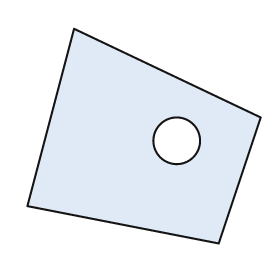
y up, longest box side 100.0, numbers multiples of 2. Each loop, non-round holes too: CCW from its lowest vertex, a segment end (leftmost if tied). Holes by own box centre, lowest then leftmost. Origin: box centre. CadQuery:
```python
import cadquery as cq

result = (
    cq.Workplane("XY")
    .moveTo(32.0, -46.0)
    .lineTo(50.0, 8.0)
    .lineTo(-30.0, 46.0)
    .lineTo(-50.0, -30.0)
    .close()
    .moveTo(14.0, -2.0)
    .circle(10.0)
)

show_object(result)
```